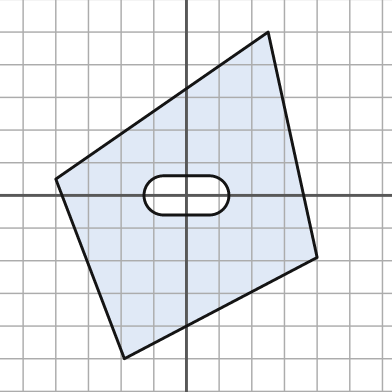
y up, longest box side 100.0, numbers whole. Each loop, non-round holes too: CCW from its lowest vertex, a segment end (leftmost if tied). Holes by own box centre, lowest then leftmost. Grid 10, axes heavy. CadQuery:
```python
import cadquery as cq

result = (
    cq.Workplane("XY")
    .moveTo(-19.0, -50.0)
    .lineTo(40.0, -19.0)
    .lineTo(25.0, 50.0)
    .lineTo(-40.0, 5.0)
    .close()
    .moveTo(-7.0, -6.0)
    .lineTo(7.0, -6.0)
    .threePointArc((13.0, 0.0), (7.0, 6.0))
    .lineTo(-7.0, 6.0)
    .threePointArc((-13.0, 0.0), (-7.0, -6.0))
    .close()
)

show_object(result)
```